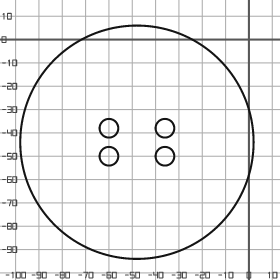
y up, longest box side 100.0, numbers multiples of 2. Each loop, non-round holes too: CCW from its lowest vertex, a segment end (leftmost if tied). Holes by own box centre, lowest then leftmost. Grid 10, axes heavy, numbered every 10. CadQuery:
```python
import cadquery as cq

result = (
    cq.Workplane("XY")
    .moveTo(-48.0, -44.0)
    .circle(50.0)
    .moveTo(-60.0, -50.0)
    .circle(4.0)
    .moveTo(-36.0, -50.0)
    .circle(4.0)
    .moveTo(-60.0, -38.0)
    .circle(4.0)
    .moveTo(-36.0, -38.0)
    .circle(4.0)
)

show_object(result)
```